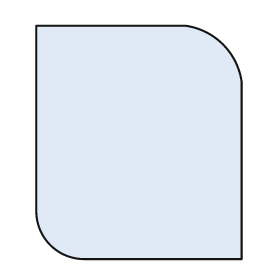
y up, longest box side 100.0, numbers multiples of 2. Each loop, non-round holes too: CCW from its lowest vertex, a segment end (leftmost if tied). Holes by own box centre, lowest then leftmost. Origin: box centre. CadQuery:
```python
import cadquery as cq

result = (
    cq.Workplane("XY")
    .moveTo(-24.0, -50.0)
    .lineTo(44.0, -50.0)
    .lineTo(44.0, 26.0)
    .threePointArc((36.0, 42.0), (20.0, 50.0))
    .lineTo(-44.0, 50.0)
    .lineTo(-44.0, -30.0)
    .threePointArc((-38.0, -44.0), (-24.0, -50.0))
    .close()
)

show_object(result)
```